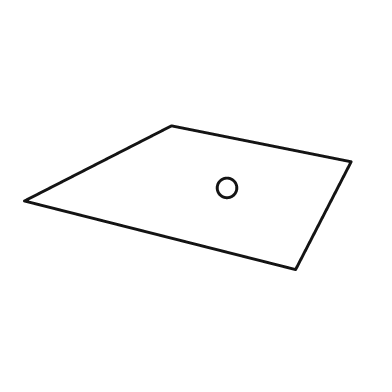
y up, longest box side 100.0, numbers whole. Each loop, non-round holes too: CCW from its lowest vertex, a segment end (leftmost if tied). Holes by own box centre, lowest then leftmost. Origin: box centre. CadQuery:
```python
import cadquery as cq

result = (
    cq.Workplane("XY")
    .moveTo(33.0, -22.0)
    .lineTo(50.0, 11.0)
    .lineTo(-5.0, 22.0)
    .lineTo(-50.0, -1.0)
    .close()
    .moveTo(12.0, 3.0)
    .circle(3.0)
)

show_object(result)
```